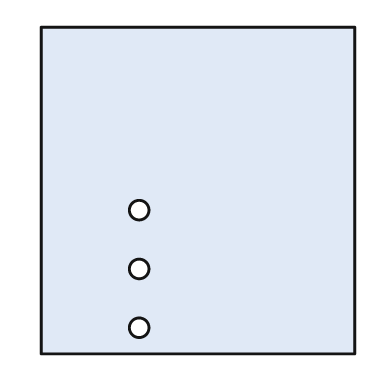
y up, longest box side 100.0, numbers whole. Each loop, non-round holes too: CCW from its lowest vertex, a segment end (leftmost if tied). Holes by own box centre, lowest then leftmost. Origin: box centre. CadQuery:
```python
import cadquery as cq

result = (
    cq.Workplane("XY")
    .moveTo(-48.0, -50.0)
    .lineTo(48.0, -50.0)
    .lineTo(48.0, 50.0)
    .lineTo(-48.0, 50.0)
    .close()
    .moveTo(-18.0, -42.0)
    .circle(3.0)
    .moveTo(-18.0, -24.0)
    .circle(3.0)
    .moveTo(-18.0, -6.0)
    .circle(3.0)
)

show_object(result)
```